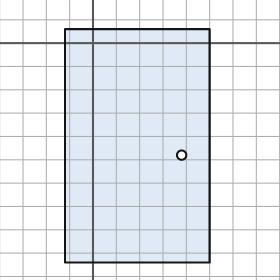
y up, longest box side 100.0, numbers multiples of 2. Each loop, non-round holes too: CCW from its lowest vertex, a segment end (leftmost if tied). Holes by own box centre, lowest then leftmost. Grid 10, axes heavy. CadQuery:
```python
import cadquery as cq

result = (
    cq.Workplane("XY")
    .moveTo(-12.0, -94.0)
    .lineTo(50.0, -94.0)
    .lineTo(50.0, 6.0)
    .lineTo(-12.0, 6.0)
    .close()
    .moveTo(38.0, -48.0)
    .circle(2.0)
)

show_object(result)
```